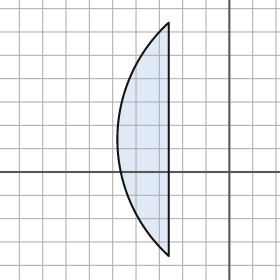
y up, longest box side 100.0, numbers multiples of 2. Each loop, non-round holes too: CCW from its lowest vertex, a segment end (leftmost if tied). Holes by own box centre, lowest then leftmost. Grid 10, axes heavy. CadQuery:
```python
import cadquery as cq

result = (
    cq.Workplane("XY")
    .moveTo(-26.0, -36.0)
    .lineTo(-26.0, 64.0)
    .threePointArc((-48.0, 14.0), (-26.0, -36.0))
    .close()
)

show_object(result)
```